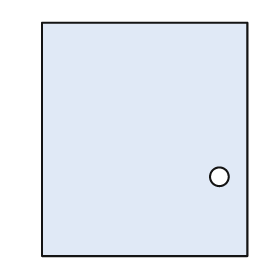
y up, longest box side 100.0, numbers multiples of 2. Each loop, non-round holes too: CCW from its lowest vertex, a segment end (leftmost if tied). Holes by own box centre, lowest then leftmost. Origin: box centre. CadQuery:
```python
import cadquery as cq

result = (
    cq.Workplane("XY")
    .moveTo(-44.0, -50.0)
    .lineTo(44.0, -50.0)
    .lineTo(44.0, 50.0)
    .lineTo(-44.0, 50.0)
    .close()
    .moveTo(32.0, -16.0)
    .circle(4.0)
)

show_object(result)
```